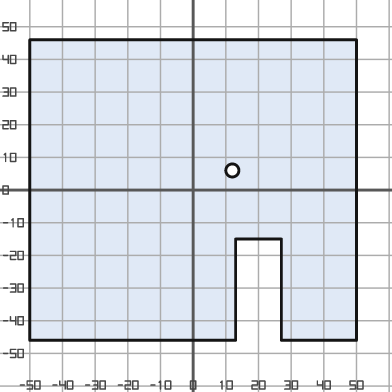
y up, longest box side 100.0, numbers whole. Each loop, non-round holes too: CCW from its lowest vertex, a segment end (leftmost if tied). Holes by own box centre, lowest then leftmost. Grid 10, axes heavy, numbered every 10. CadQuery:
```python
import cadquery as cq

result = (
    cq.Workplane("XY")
    .moveTo(-50.0, -46.0)
    .lineTo(13.0, -46.0)
    .lineTo(13.0, -15.0)
    .lineTo(27.0, -15.0)
    .lineTo(27.0, -46.0)
    .lineTo(50.0, -46.0)
    .lineTo(50.0, 46.0)
    .lineTo(-50.0, 46.0)
    .close()
    .moveTo(12.0, 6.0)
    .circle(2.0)
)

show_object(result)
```